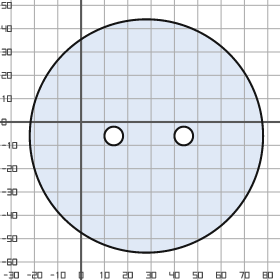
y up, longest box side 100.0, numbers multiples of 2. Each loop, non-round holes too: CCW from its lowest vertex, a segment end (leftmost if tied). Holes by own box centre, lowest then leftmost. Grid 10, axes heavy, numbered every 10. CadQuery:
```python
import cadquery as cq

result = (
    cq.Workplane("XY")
    .moveTo(28.0, -6.0)
    .circle(50.0)
    .moveTo(14.0, -6.0)
    .circle(4.0)
    .moveTo(44.0, -6.0)
    .circle(4.0)
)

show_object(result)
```